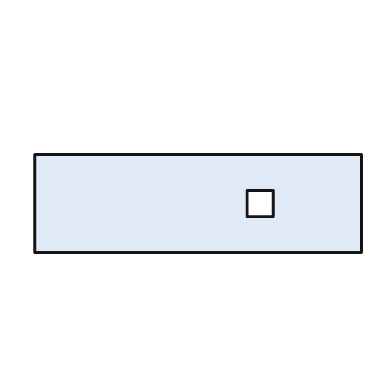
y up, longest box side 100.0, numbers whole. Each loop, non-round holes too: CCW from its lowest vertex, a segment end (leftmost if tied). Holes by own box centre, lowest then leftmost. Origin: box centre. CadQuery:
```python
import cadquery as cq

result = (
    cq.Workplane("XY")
    .moveTo(-50.0, -15.0)
    .lineTo(50.0, -15.0)
    .lineTo(50.0, 15.0)
    .lineTo(-50.0, 15.0)
    .close()
    .moveTo(15.0, -4.0)
    .lineTo(23.0, -4.0)
    .lineTo(23.0, 4.0)
    .lineTo(15.0, 4.0)
    .close()
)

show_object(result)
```